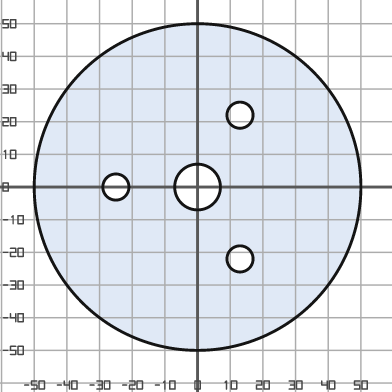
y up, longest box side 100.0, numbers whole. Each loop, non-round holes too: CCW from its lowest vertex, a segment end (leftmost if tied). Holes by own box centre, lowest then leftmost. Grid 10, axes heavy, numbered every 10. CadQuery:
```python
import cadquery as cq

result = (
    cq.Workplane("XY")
    .moveTo(0.0, 0.0)
    .circle(50.0)
    .moveTo(13.0, -22.0)
    .circle(4.0)
    .moveTo(-25.0, 0.0)
    .circle(4.0)
    .moveTo(0.0, 0.0)
    .circle(7.0)
    .moveTo(13.0, 22.0)
    .circle(4.0)
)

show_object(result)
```